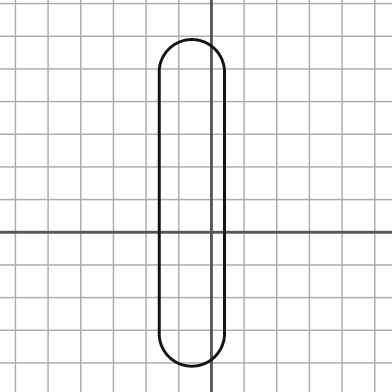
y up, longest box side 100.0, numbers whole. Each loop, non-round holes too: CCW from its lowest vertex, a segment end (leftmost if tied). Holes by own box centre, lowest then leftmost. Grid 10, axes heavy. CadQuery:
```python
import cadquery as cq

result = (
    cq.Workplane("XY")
    .moveTo(-16.0, -31.0)
    .threePointArc((-6.0, -41.0), (4.0, -31.0))
    .lineTo(4.0, 49.0)
    .threePointArc((-6.0, 59.0), (-16.0, 49.0))
    .close()
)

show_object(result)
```